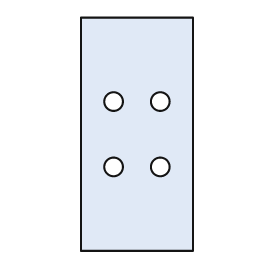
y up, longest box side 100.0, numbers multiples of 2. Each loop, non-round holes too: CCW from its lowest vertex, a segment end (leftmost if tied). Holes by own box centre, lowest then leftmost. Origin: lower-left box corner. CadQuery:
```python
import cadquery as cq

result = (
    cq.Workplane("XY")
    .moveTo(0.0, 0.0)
    .lineTo(48.0, 0.0)
    .lineTo(48.0, 100.0)
    .lineTo(0.0, 100.0)
    .close()
    .moveTo(14.0, 36.0)
    .circle(4.0)
    .moveTo(34.0, 36.0)
    .circle(4.0)
    .moveTo(14.0, 64.0)
    .circle(4.0)
    .moveTo(34.0, 64.0)
    .circle(4.0)
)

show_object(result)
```